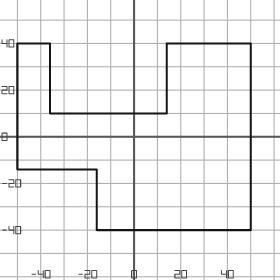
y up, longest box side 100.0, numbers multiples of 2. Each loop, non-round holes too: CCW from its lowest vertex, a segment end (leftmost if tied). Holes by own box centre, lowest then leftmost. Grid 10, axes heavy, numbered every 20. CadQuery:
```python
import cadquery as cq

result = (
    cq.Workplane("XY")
    .moveTo(-16.0, -40.0)
    .lineTo(50.0, -40.0)
    .lineTo(50.0, 40.0)
    .lineTo(14.0, 40.0)
    .lineTo(14.0, 10.0)
    .lineTo(-36.0, 10.0)
    .lineTo(-36.0, 40.0)
    .lineTo(-50.0, 40.0)
    .lineTo(-50.0, -14.0)
    .lineTo(-16.0, -14.0)
    .close()
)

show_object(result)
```